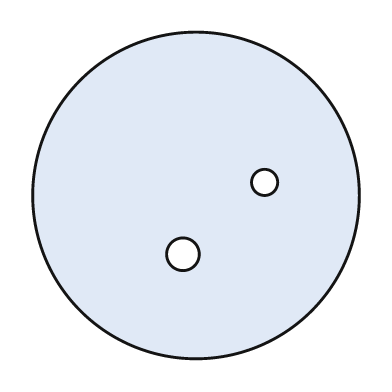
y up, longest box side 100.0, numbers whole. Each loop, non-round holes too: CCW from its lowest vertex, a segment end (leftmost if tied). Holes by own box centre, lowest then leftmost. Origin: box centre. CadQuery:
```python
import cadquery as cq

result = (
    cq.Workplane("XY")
    .moveTo(0.0, 0.0)
    .circle(50.0)
    .moveTo(-4.0, -18.0)
    .circle(5.0)
    .moveTo(21.0, 4.0)
    .circle(4.0)
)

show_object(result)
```